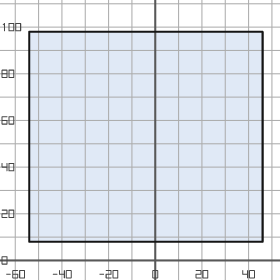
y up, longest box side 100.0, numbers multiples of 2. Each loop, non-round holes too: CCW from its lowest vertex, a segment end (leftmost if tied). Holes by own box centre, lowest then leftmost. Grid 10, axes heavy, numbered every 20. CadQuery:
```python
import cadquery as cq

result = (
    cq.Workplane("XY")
    .moveTo(-54.0, 8.0)
    .lineTo(46.0, 8.0)
    .lineTo(46.0, 98.0)
    .lineTo(-54.0, 98.0)
    .close()
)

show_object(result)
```